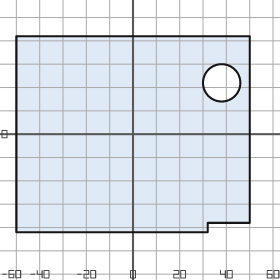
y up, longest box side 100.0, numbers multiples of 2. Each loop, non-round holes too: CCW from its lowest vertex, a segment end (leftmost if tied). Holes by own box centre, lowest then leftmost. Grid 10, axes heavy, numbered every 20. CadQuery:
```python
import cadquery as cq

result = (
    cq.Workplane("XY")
    .moveTo(-50.0, -42.0)
    .lineTo(32.0, -42.0)
    .lineTo(32.0, -38.0)
    .lineTo(50.0, -38.0)
    .lineTo(50.0, 42.0)
    .lineTo(-50.0, 42.0)
    .close()
    .moveTo(38.0, 22.0)
    .circle(8.0)
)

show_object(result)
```